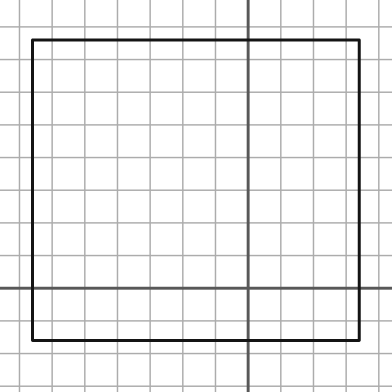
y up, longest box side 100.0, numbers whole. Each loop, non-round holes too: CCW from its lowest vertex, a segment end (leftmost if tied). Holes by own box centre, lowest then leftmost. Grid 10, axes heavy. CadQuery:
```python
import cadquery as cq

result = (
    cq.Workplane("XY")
    .moveTo(-66.0, -16.0)
    .lineTo(34.0, -16.0)
    .lineTo(34.0, 76.0)
    .lineTo(-66.0, 76.0)
    .close()
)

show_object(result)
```